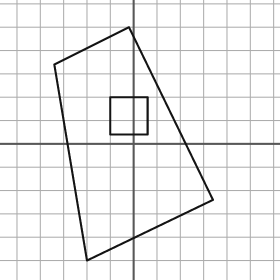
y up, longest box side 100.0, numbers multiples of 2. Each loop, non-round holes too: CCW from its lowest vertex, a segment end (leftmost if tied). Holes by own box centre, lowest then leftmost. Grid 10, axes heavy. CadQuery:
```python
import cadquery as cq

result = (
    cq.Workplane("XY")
    .moveTo(-20.0, -50.0)
    .lineTo(34.0, -24.0)
    .lineTo(-2.0, 50.0)
    .lineTo(-34.0, 34.0)
    .close()
    .moveTo(-10.0, 4.0)
    .lineTo(6.0, 4.0)
    .lineTo(6.0, 20.0)
    .lineTo(-10.0, 20.0)
    .close()
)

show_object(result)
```